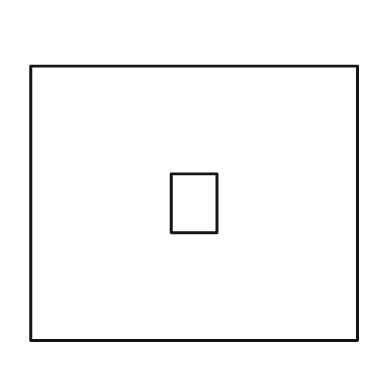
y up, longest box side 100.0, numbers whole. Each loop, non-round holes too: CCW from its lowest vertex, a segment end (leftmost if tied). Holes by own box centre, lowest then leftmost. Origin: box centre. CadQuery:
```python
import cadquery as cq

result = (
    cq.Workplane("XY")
    .moveTo(-50.0, -42.0)
    .lineTo(50.0, -42.0)
    .lineTo(50.0, 42.0)
    .lineTo(-50.0, 42.0)
    .close()
    .moveTo(-7.0, -9.0)
    .lineTo(7.0, -9.0)
    .lineTo(7.0, 9.0)
    .lineTo(-7.0, 9.0)
    .close()
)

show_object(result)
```